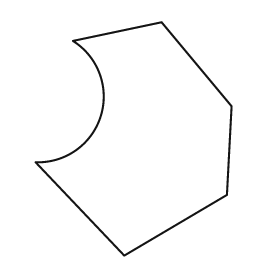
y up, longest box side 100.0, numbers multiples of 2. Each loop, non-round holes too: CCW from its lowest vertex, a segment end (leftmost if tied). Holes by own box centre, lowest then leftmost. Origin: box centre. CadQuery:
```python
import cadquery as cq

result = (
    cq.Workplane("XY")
    .moveTo(-4.0, -50.0)
    .lineTo(40.0, -24.0)
    .lineTo(42.0, 14.0)
    .lineTo(12.0, 50.0)
    .lineTo(-26.0, 42.0)
    .threePointArc((-14.0, 10.0), (-42.0, -10.0))
    .close()
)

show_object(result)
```